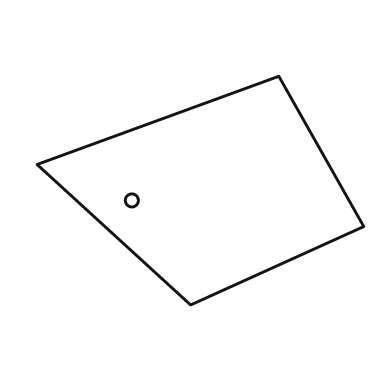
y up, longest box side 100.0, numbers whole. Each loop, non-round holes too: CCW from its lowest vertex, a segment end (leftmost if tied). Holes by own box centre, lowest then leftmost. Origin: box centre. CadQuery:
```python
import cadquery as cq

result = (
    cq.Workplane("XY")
    .moveTo(-3.0, -35.0)
    .lineTo(50.0, -11.0)
    .lineTo(24.0, 35.0)
    .lineTo(-50.0, 8.0)
    .close()
    .moveTo(-21.0, -3.0)
    .circle(2.0)
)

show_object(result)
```